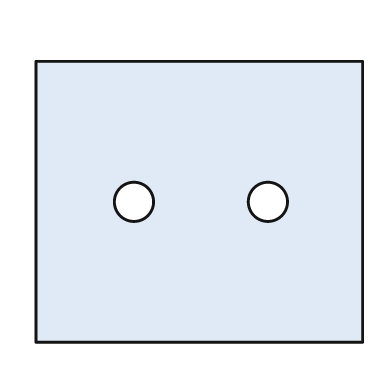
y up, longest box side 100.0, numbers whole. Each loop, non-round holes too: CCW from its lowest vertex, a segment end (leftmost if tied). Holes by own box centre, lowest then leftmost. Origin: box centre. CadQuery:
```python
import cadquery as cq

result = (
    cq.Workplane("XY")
    .moveTo(-50.0, -43.0)
    .lineTo(50.0, -43.0)
    .lineTo(50.0, 43.0)
    .lineTo(-50.0, 43.0)
    .close()
    .moveTo(-20.0, 0.0)
    .circle(6.0)
    .moveTo(21.0, 0.0)
    .circle(6.0)
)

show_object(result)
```